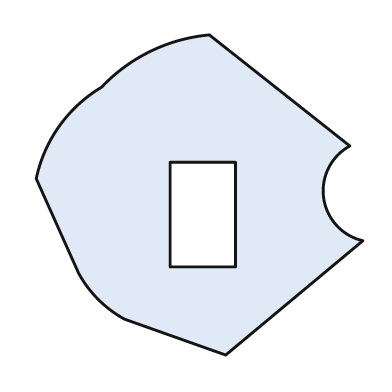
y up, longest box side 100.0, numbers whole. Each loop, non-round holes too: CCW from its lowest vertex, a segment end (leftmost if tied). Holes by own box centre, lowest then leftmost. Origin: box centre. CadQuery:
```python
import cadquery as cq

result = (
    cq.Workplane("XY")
    .moveTo(8.0, -49.0)
    .lineTo(50.0, -14.0)
    .threePointArc((38.0, -1.0), (46.0, 15.0))
    .lineTo(3.0, 49.0)
    .threePointArc((-15.0, 44.0), (-30.0, 33.0))
    .threePointArc((-43.0, 21.0), (-50.0, 5.0))
    .lineTo(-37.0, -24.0)
    .threePointArc((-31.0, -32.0), (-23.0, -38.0))
    .close()
    .moveTo(-9.0, -22.0)
    .lineTo(11.0, -22.0)
    .lineTo(11.0, 10.0)
    .lineTo(-9.0, 10.0)
    .close()
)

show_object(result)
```